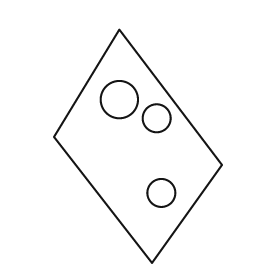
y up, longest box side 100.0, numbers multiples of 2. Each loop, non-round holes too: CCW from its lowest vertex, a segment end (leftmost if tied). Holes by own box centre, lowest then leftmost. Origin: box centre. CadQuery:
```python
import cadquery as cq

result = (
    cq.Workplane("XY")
    .moveTo(6.0, -50.0)
    .lineTo(36.0, -8.0)
    .lineTo(-8.0, 50.0)
    .lineTo(-36.0, 4.0)
    .close()
    .moveTo(10.0, -20.0)
    .circle(6.0)
    .moveTo(8.0, 12.0)
    .circle(6.0)
    .moveTo(-8.0, 20.0)
    .circle(8.0)
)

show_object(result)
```